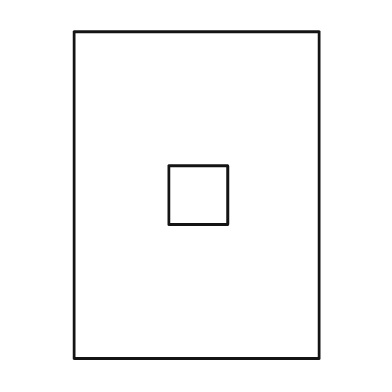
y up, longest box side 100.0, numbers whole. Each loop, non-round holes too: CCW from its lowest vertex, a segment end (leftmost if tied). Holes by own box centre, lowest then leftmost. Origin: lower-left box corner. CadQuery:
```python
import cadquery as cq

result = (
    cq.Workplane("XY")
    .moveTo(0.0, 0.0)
    .lineTo(75.0, 0.0)
    .lineTo(75.0, 100.0)
    .lineTo(0.0, 100.0)
    .close()
    .moveTo(29.0, 41.0)
    .lineTo(47.0, 41.0)
    .lineTo(47.0, 59.0)
    .lineTo(29.0, 59.0)
    .close()
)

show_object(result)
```